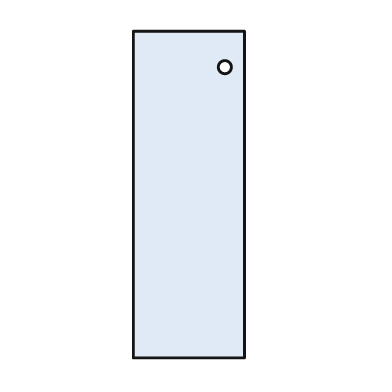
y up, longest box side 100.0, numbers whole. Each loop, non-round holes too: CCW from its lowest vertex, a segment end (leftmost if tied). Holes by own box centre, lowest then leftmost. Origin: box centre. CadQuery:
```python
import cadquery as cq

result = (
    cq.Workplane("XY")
    .moveTo(-17.0, -50.0)
    .lineTo(17.0, -50.0)
    .lineTo(17.0, 50.0)
    .lineTo(-17.0, 50.0)
    .close()
    .moveTo(11.0, 39.0)
    .circle(2.0)
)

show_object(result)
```